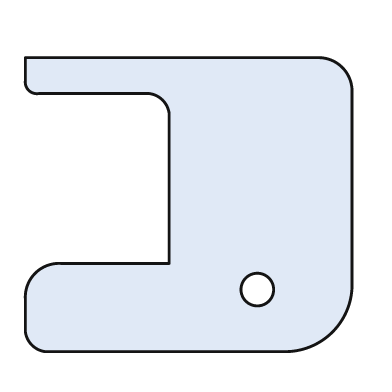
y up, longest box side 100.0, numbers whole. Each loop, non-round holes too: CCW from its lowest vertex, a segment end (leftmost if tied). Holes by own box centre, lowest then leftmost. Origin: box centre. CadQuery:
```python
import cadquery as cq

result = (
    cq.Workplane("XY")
    .moveTo(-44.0, -45.0)
    .lineTo(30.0, -45.0)
    .threePointArc((44.0, -39.0), (50.0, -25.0))
    .lineTo(50.0, 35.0)
    .threePointArc((47.0, 42.0), (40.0, 45.0))
    .lineTo(-50.0, 45.0)
    .lineTo(-50.0, 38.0)
    .threePointArc((-49.0, 35.0), (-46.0, 34.0))
    .lineTo(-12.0, 34.0)
    .threePointArc((-8.0, 32.0), (-6.0, 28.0))
    .lineTo(-6.0, -18.0)
    .lineTo(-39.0, -18.0)
    .threePointArc((-47.0, -21.0), (-50.0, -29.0))
    .lineTo(-50.0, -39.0)
    .threePointArc((-48.0, -43.0), (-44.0, -45.0))
    .close()
    .moveTo(21.0, -26.0)
    .circle(5.0)
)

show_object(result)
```